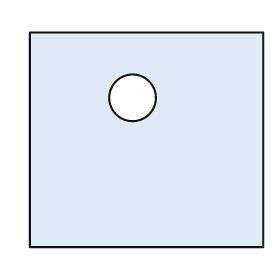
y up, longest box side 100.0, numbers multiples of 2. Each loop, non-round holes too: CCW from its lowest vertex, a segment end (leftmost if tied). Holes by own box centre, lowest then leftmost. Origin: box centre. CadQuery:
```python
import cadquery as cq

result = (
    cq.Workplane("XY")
    .moveTo(-50.0, -46.0)
    .lineTo(50.0, -46.0)
    .lineTo(50.0, 46.0)
    .lineTo(-50.0, 46.0)
    .close()
    .moveTo(-6.0, 18.0)
    .circle(10.0)
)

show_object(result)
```